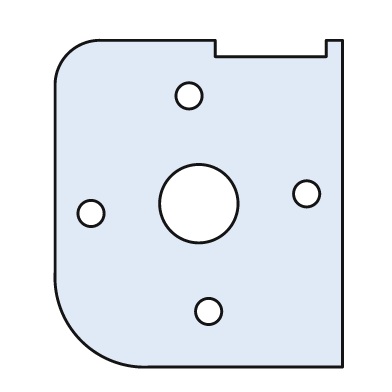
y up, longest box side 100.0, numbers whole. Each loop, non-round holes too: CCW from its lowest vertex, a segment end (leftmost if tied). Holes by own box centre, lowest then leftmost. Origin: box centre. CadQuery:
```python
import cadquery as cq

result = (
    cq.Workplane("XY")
    .moveTo(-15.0, -50.0)
    .lineTo(44.0, -50.0)
    .lineTo(44.0, 50.0)
    .lineTo(39.0, 50.0)
    .lineTo(39.0, 45.0)
    .lineTo(5.0, 45.0)
    .lineTo(5.0, 50.0)
    .lineTo(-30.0, 50.0)
    .threePointArc((-40.0, 46.0), (-44.0, 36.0))
    .lineTo(-44.0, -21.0)
    .threePointArc((-36.0, -42.0), (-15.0, -50.0))
    .close()
    .moveTo(3.0, -33.0)
    .circle(4.0)
    .moveTo(-33.0, -3.0)
    .circle(4.0)
    .moveTo(0.0, 0.0)
    .circle(12.0)
    .moveTo(33.0, 3.0)
    .circle(4.0)
    .moveTo(-3.0, 33.0)
    .circle(4.0)
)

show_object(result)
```